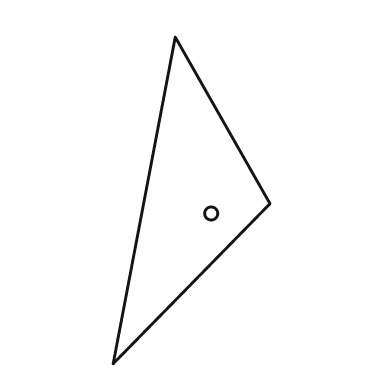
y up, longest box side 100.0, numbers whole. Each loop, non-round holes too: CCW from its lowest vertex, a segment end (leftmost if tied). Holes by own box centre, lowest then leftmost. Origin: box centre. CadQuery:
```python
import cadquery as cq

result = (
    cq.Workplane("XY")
    .moveTo(-24.0, -50.0)
    .lineTo(24.0, -1.0)
    .lineTo(-5.0, 50.0)
    .close()
    .moveTo(6.0, -4.0)
    .circle(2.0)
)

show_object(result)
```